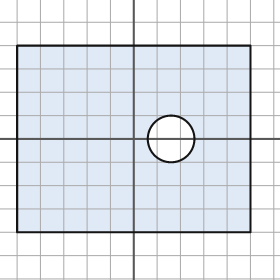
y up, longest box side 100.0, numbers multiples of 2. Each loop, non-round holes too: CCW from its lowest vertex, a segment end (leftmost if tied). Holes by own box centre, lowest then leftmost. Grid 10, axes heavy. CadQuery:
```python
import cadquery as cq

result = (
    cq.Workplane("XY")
    .moveTo(-50.0, -40.0)
    .lineTo(50.0, -40.0)
    .lineTo(50.0, 40.0)
    .lineTo(-50.0, 40.0)
    .close()
    .moveTo(16.0, 0.0)
    .circle(10.0)
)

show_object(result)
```